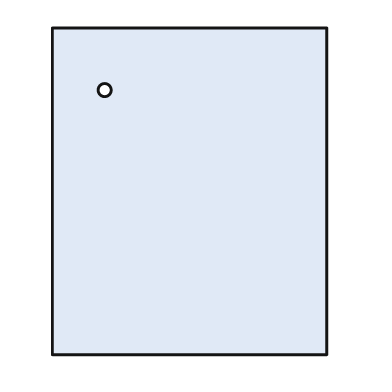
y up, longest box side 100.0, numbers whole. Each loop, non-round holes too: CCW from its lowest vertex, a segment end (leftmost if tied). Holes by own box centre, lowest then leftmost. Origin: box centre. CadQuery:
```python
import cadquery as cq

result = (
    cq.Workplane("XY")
    .moveTo(-42.0, -50.0)
    .lineTo(42.0, -50.0)
    .lineTo(42.0, 50.0)
    .lineTo(-42.0, 50.0)
    .close()
    .moveTo(-26.0, 31.0)
    .circle(2.0)
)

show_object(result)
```